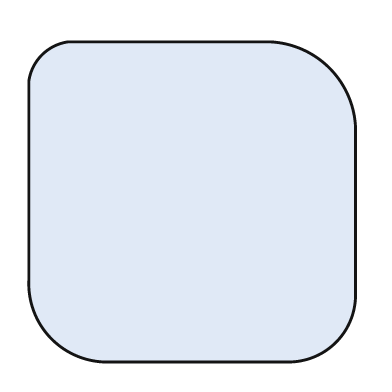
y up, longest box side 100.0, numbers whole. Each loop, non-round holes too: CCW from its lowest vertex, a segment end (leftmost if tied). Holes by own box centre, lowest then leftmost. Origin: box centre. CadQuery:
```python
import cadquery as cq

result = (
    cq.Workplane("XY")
    .moveTo(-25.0, -49.0)
    .lineTo(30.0, -49.0)
    .threePointArc((44.0, -43.0), (50.0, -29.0))
    .lineTo(50.0, 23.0)
    .threePointArc((42.0, 41.0), (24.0, 49.0))
    .lineTo(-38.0, 49.0)
    .threePointArc((-46.0, 45.0), (-50.0, 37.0))
    .lineTo(-50.0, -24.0)
    .threePointArc((-43.0, -42.0), (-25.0, -49.0))
    .close()
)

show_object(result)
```